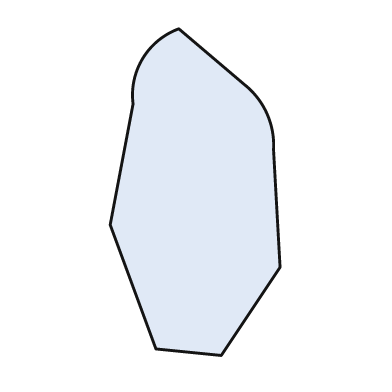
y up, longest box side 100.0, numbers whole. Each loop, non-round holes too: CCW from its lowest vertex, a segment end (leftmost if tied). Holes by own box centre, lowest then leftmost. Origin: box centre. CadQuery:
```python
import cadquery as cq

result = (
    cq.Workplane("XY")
    .moveTo(8.0, -50.0)
    .lineTo(26.0, -23.0)
    .lineTo(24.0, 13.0)
    .threePointArc((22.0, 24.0), (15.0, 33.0))
    .lineTo(-5.0, 50.0)
    .threePointArc((-16.0, 41.0), (-19.0, 27.0))
    .lineTo(-26.0, -10.0)
    .lineTo(-12.0, -48.0)
    .close()
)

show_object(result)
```